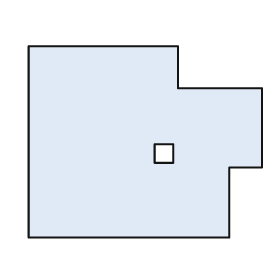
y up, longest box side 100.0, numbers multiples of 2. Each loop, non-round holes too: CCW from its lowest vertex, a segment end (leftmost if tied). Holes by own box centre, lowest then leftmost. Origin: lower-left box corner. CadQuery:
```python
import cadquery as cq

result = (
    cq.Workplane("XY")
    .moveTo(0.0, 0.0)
    .lineTo(86.0, 0.0)
    .lineTo(86.0, 30.0)
    .lineTo(100.0, 30.0)
    .lineTo(100.0, 64.0)
    .lineTo(64.0, 64.0)
    .lineTo(64.0, 82.0)
    .lineTo(0.0, 82.0)
    .close()
    .moveTo(54.0, 32.0)
    .lineTo(62.0, 32.0)
    .lineTo(62.0, 40.0)
    .lineTo(54.0, 40.0)
    .close()
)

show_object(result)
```